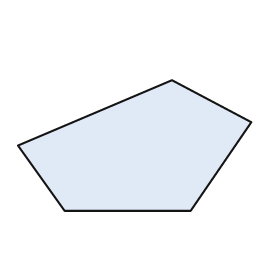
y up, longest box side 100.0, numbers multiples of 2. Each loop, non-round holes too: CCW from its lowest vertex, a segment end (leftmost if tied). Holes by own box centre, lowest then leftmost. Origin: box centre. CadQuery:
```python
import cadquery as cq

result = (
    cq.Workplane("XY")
    .moveTo(-30.0, -28.0)
    .lineTo(24.0, -28.0)
    .lineTo(50.0, 10.0)
    .lineTo(16.0, 28.0)
    .lineTo(-50.0, 0.0)
    .close()
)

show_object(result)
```